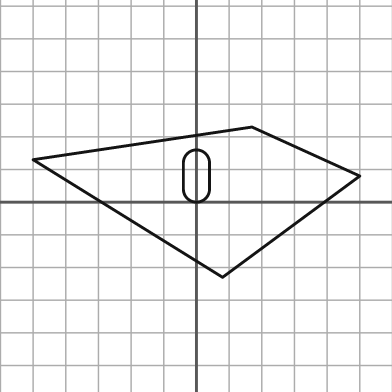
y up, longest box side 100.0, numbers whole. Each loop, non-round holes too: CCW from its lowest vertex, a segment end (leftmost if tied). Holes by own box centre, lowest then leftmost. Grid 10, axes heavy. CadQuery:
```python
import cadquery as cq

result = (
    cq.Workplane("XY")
    .moveTo(8.0, -23.0)
    .lineTo(50.0, 8.0)
    .lineTo(17.0, 23.0)
    .lineTo(-50.0, 13.0)
    .close()
    .moveTo(-4.0, 4.0)
    .threePointArc((0.0, 0.0), (4.0, 4.0))
    .lineTo(4.0, 12.0)
    .threePointArc((0.0, 16.0), (-4.0, 12.0))
    .close()
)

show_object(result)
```